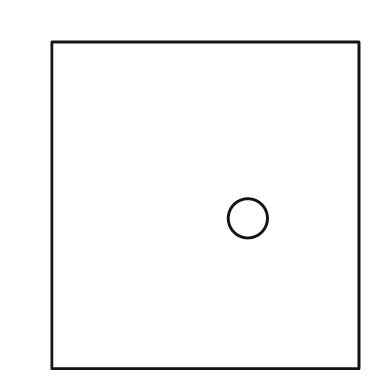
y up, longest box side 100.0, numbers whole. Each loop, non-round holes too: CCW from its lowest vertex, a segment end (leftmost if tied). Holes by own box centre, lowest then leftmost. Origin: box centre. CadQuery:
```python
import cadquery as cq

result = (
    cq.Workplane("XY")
    .moveTo(-47.0, -50.0)
    .lineTo(47.0, -50.0)
    .lineTo(47.0, 50.0)
    .lineTo(-47.0, 50.0)
    .close()
    .moveTo(13.0, -4.0)
    .circle(6.0)
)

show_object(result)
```